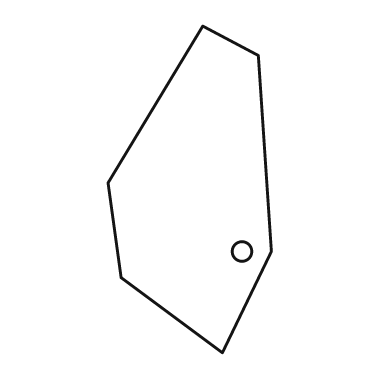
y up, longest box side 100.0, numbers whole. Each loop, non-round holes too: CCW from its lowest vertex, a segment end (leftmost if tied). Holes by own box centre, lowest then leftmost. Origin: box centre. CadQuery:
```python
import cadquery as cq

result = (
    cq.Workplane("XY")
    .moveTo(10.0, -50.0)
    .lineTo(25.0, -19.0)
    .lineTo(21.0, 41.0)
    .lineTo(4.0, 50.0)
    .lineTo(-25.0, 2.0)
    .lineTo(-21.0, -27.0)
    .close()
    .moveTo(16.0, -19.0)
    .circle(3.0)
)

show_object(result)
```